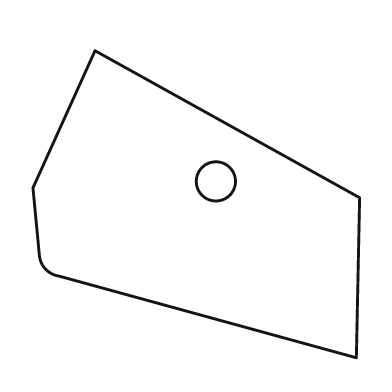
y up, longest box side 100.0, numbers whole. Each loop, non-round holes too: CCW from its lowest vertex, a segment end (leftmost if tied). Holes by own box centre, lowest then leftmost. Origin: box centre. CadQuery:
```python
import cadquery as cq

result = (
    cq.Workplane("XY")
    .moveTo(49.0, -47.0)
    .lineTo(50.0, 2.0)
    .lineTo(-31.0, 47.0)
    .lineTo(-50.0, 5.0)
    .lineTo(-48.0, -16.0)
    .threePointArc((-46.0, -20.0), (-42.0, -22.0))
    .close()
    .moveTo(6.0, 7.0)
    .circle(6.0)
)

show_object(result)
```